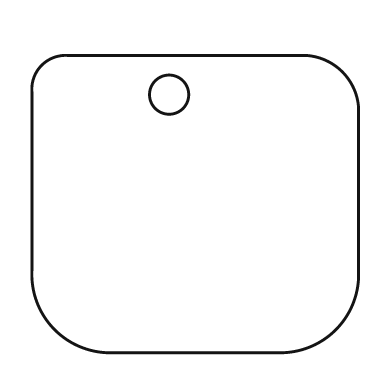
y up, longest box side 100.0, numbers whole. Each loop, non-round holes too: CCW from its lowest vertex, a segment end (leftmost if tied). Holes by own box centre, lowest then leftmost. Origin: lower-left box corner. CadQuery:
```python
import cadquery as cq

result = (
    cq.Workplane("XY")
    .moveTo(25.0, 0.0)
    .lineTo(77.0, 0.0)
    .threePointArc((93.0, 7.0), (100.0, 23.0))
    .lineTo(100.0, 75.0)
    .threePointArc((95.0, 86.0), (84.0, 91.0))
    .lineTo(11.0, 91.0)
    .threePointArc((3.0, 88.0), (0.0, 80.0))
    .lineTo(0.0, 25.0)
    .threePointArc((7.0, 7.0), (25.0, 0.0))
    .close()
    .moveTo(42.0, 79.0)
    .circle(6.0)
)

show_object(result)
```